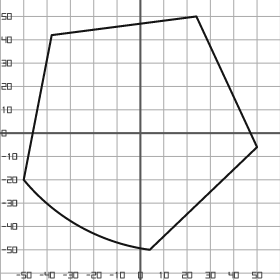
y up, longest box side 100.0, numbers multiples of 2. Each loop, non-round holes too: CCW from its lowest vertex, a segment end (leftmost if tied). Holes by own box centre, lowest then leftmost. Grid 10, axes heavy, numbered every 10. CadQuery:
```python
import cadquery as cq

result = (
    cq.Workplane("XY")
    .moveTo(4.0, -50.0)
    .lineTo(50.0, -6.0)
    .lineTo(24.0, 50.0)
    .lineTo(-38.0, 42.0)
    .lineTo(-50.0, -20.0)
    .threePointArc((-26.0, -40.0), (4.0, -50.0))
    .close()
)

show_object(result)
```